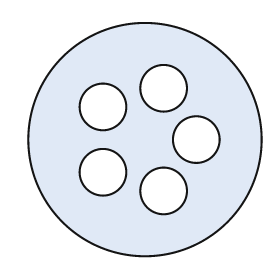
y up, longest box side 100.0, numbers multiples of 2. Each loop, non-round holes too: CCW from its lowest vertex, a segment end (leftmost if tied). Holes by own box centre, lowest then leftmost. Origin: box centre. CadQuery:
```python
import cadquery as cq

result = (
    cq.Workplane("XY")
    .moveTo(0.0, 0.0)
    .circle(50.0)
    .moveTo(8.0, -22.0)
    .circle(10.0)
    .moveTo(-18.0, -14.0)
    .circle(10.0)
    .moveTo(22.0, 0.0)
    .circle(10.0)
    .moveTo(-18.0, 14.0)
    .circle(10.0)
    .moveTo(8.0, 22.0)
    .circle(10.0)
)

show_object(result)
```